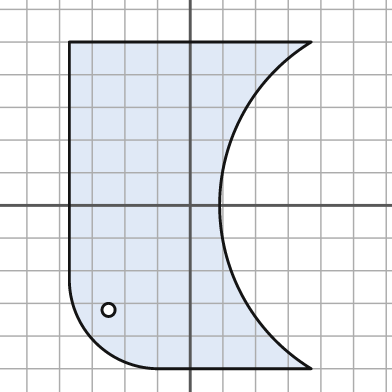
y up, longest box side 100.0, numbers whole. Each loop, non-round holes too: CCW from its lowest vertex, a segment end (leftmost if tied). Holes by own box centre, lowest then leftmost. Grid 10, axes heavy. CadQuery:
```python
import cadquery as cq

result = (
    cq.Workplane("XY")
    .moveTo(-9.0, -50.0)
    .lineTo(37.0, -50.0)
    .threePointArc((9.0, 0.0), (37.0, 50.0))
    .lineTo(-37.0, 50.0)
    .lineTo(-37.0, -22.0)
    .threePointArc((-29.0, -42.0), (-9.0, -50.0))
    .close()
    .moveTo(-25.0, -32.0)
    .circle(2.0)
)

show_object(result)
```